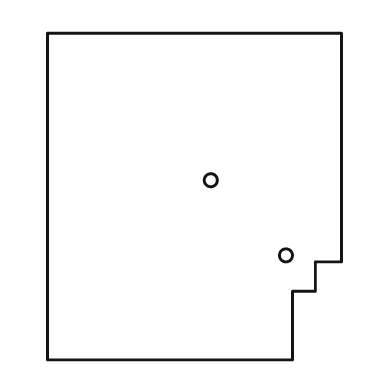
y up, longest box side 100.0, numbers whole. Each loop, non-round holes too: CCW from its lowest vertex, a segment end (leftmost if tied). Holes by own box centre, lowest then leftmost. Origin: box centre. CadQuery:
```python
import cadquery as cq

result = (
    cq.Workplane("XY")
    .moveTo(-45.0, -50.0)
    .lineTo(30.0, -50.0)
    .lineTo(30.0, -29.0)
    .lineTo(37.0, -29.0)
    .lineTo(37.0, -20.0)
    .lineTo(45.0, -20.0)
    .lineTo(45.0, 50.0)
    .lineTo(-45.0, 50.0)
    .close()
    .moveTo(28.0, -18.0)
    .circle(2.0)
    .moveTo(5.0, 5.0)
    .circle(2.0)
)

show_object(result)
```